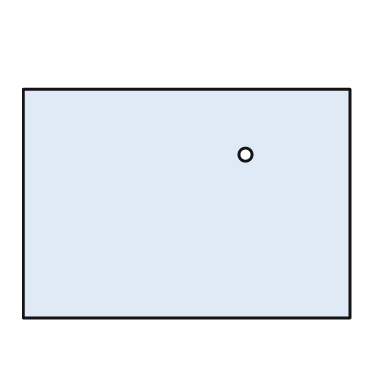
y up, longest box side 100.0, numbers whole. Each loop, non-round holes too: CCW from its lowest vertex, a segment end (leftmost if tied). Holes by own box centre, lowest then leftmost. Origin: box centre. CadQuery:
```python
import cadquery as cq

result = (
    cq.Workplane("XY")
    .moveTo(-50.0, -35.0)
    .lineTo(50.0, -35.0)
    .lineTo(50.0, 35.0)
    .lineTo(-50.0, 35.0)
    .close()
    .moveTo(18.0, 15.0)
    .circle(2.0)
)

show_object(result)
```